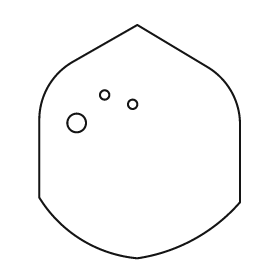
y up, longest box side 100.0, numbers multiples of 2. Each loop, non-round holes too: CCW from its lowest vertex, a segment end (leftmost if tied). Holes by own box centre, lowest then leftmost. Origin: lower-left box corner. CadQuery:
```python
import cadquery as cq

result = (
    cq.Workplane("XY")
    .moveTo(42.0, 0.0)
    .threePointArc((66.0, 8.0), (86.0, 24.0))
    .lineTo(86.0, 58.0)
    .threePointArc((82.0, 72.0), (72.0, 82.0))
    .lineTo(42.0, 100.0)
    .lineTo(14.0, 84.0)
    .threePointArc((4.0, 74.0), (0.0, 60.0))
    .lineTo(0.0, 26.0)
    .threePointArc((18.0, 8.0), (42.0, 0.0))
    .close()
    .moveTo(16.0, 58.0)
    .circle(4.0)
    .moveTo(40.0, 66.0)
    .circle(2.0)
    .moveTo(28.0, 70.0)
    .circle(2.0)
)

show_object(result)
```